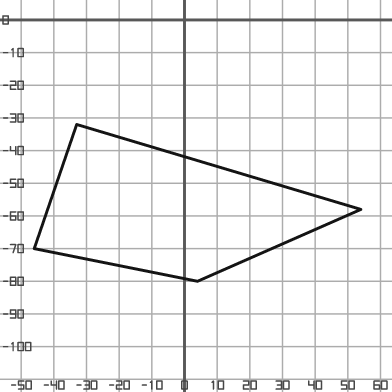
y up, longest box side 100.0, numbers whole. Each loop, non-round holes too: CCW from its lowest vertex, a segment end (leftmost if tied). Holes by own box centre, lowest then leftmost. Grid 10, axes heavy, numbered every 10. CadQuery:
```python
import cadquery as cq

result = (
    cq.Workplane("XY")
    .moveTo(4.0, -80.0)
    .lineTo(54.0, -58.0)
    .lineTo(-33.0, -32.0)
    .lineTo(-46.0, -70.0)
    .close()
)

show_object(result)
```